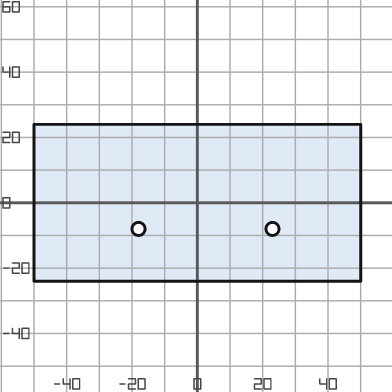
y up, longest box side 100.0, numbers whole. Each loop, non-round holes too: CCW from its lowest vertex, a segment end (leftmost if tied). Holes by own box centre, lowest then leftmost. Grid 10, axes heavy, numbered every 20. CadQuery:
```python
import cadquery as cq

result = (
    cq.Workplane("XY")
    .moveTo(-50.0, -24.0)
    .lineTo(50.0, -24.0)
    .lineTo(50.0, 24.0)
    .lineTo(-50.0, 24.0)
    .close()
    .moveTo(-18.0, -8.0)
    .circle(2.0)
    .moveTo(23.0, -8.0)
    .circle(2.0)
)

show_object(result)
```